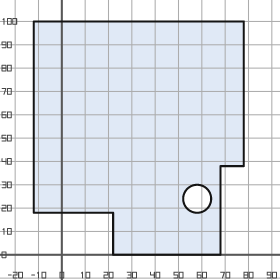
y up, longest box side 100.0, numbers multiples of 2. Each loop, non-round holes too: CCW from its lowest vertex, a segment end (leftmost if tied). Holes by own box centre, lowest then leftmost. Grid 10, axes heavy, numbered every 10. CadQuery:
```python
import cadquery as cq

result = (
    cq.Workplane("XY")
    .moveTo(22.0, 0.0)
    .lineTo(68.0, 0.0)
    .lineTo(68.0, 38.0)
    .lineTo(78.0, 38.0)
    .lineTo(78.0, 100.0)
    .lineTo(-12.0, 100.0)
    .lineTo(-12.0, 18.0)
    .lineTo(22.0, 18.0)
    .close()
    .moveTo(58.0, 24.0)
    .circle(6.0)
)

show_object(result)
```